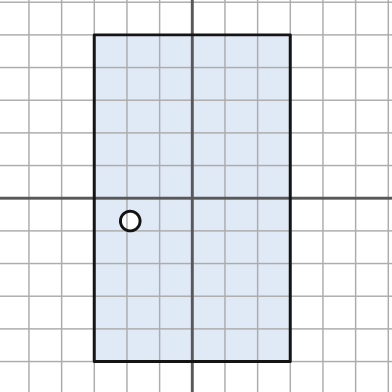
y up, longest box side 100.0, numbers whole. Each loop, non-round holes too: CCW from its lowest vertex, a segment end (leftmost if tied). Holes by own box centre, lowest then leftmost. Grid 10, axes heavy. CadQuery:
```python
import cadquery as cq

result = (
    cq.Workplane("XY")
    .moveTo(-30.0, -50.0)
    .lineTo(30.0, -50.0)
    .lineTo(30.0, 50.0)
    .lineTo(-30.0, 50.0)
    .close()
    .moveTo(-19.0, -7.0)
    .circle(3.0)
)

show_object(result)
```